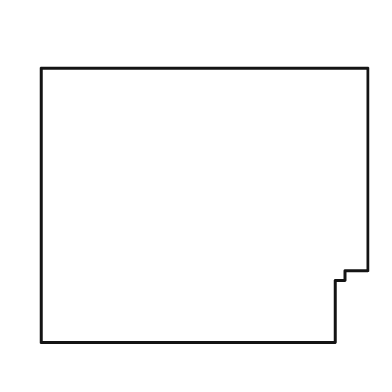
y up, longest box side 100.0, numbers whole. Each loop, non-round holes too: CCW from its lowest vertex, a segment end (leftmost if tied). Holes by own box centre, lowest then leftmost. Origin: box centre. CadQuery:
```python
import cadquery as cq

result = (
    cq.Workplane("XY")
    .moveTo(-50.0, -42.0)
    .lineTo(40.0, -42.0)
    .lineTo(40.0, -23.0)
    .lineTo(43.0, -23.0)
    .lineTo(43.0, -20.0)
    .lineTo(50.0, -20.0)
    .lineTo(50.0, 42.0)
    .lineTo(-50.0, 42.0)
    .close()
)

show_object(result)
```